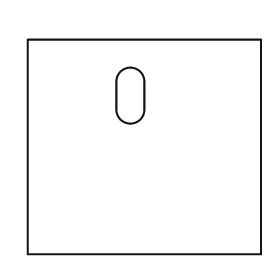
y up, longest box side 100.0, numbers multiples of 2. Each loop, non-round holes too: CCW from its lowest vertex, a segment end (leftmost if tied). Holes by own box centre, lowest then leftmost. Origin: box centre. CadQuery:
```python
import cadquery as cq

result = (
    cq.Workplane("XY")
    .moveTo(-50.0, -46.0)
    .lineTo(50.0, -46.0)
    .lineTo(50.0, 46.0)
    .lineTo(-50.0, 46.0)
    .close()
    .moveTo(-12.0, 16.0)
    .threePointArc((-6.0, 10.0), (0.0, 16.0))
    .lineTo(0.0, 28.0)
    .threePointArc((-6.0, 34.0), (-12.0, 28.0))
    .close()
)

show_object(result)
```